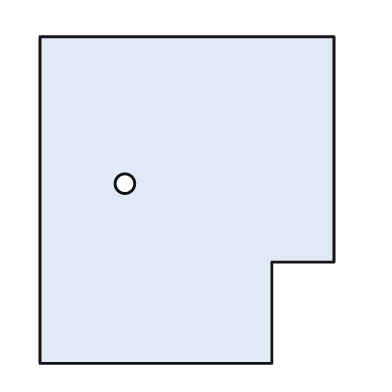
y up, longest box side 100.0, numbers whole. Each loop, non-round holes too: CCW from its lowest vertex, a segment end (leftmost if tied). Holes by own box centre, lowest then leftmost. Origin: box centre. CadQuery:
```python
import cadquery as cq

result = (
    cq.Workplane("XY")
    .moveTo(-45.0, -50.0)
    .lineTo(26.0, -50.0)
    .lineTo(26.0, -19.0)
    .lineTo(45.0, -19.0)
    .lineTo(45.0, 50.0)
    .lineTo(-45.0, 50.0)
    .close()
    .moveTo(-19.0, 5.0)
    .circle(3.0)
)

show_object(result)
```